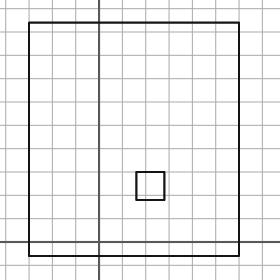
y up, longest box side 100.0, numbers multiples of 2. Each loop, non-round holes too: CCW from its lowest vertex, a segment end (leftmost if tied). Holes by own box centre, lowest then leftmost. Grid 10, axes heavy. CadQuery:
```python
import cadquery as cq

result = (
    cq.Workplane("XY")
    .moveTo(-30.0, -6.0)
    .lineTo(60.0, -6.0)
    .lineTo(60.0, 94.0)
    .lineTo(-30.0, 94.0)
    .close()
    .moveTo(16.0, 18.0)
    .lineTo(28.0, 18.0)
    .lineTo(28.0, 30.0)
    .lineTo(16.0, 30.0)
    .close()
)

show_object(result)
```